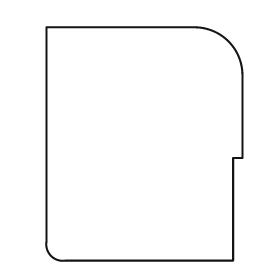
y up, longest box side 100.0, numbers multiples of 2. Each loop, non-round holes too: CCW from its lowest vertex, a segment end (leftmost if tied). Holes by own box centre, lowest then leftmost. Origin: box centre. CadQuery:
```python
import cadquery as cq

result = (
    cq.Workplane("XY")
    .moveTo(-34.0, -50.0)
    .lineTo(38.0, -50.0)
    .lineTo(38.0, -6.0)
    .lineTo(42.0, -6.0)
    .lineTo(42.0, 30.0)
    .threePointArc((36.0, 44.0), (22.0, 50.0))
    .lineTo(-42.0, 50.0)
    .lineTo(-42.0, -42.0)
    .threePointArc((-40.0, -48.0), (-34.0, -50.0))
    .close()
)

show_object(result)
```